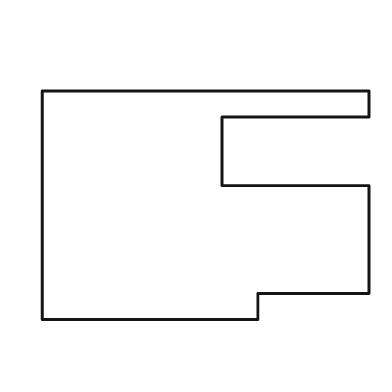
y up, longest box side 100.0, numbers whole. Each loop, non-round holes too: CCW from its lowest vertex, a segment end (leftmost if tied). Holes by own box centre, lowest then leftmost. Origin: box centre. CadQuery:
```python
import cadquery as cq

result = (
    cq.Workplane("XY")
    .moveTo(-50.0, -35.0)
    .lineTo(16.0, -35.0)
    .lineTo(16.0, -27.0)
    .lineTo(50.0, -27.0)
    .lineTo(50.0, 6.0)
    .lineTo(5.0, 6.0)
    .lineTo(5.0, 27.0)
    .lineTo(50.0, 27.0)
    .lineTo(50.0, 35.0)
    .lineTo(-50.0, 35.0)
    .close()
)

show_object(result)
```